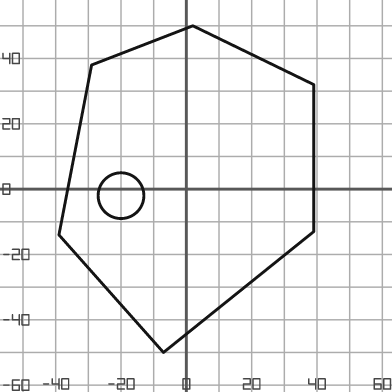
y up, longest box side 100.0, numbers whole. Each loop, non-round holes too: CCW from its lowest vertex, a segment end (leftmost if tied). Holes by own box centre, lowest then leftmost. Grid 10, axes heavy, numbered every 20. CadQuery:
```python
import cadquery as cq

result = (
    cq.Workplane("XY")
    .moveTo(-7.0, -50.0)
    .lineTo(39.0, -13.0)
    .lineTo(39.0, 32.0)
    .lineTo(2.0, 50.0)
    .lineTo(-29.0, 38.0)
    .lineTo(-39.0, -14.0)
    .close()
    .moveTo(-20.0, -2.0)
    .circle(7.0)
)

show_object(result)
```